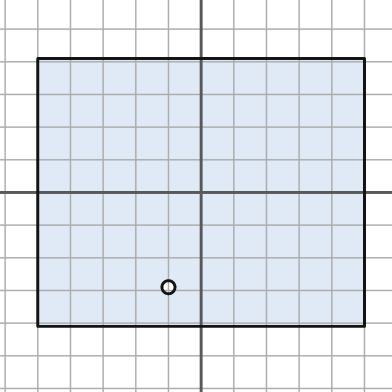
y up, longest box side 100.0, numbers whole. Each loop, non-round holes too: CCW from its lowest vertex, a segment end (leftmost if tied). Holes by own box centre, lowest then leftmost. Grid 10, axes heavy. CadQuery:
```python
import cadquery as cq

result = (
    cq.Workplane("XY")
    .moveTo(-50.0, -41.0)
    .lineTo(50.0, -41.0)
    .lineTo(50.0, 41.0)
    .lineTo(-50.0, 41.0)
    .close()
    .moveTo(-10.0, -29.0)
    .circle(2.0)
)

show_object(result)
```